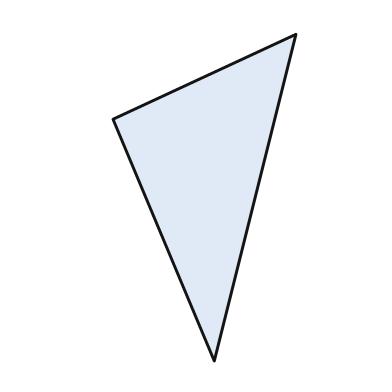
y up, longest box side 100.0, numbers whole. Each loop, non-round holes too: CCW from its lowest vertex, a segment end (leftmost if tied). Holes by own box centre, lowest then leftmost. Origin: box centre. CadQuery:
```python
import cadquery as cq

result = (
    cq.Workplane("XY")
    .moveTo(3.0, -50.0)
    .lineTo(28.0, 50.0)
    .lineTo(-28.0, 24.0)
    .close()
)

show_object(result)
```